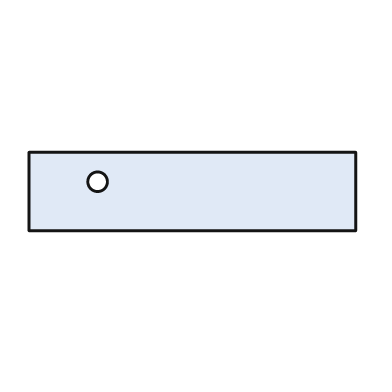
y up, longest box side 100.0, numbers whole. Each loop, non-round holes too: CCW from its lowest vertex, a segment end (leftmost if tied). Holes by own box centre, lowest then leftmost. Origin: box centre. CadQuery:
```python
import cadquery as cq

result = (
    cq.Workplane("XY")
    .moveTo(-50.0, -12.0)
    .lineTo(50.0, -12.0)
    .lineTo(50.0, 12.0)
    .lineTo(-50.0, 12.0)
    .close()
    .moveTo(-29.0, 3.0)
    .circle(3.0)
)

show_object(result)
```